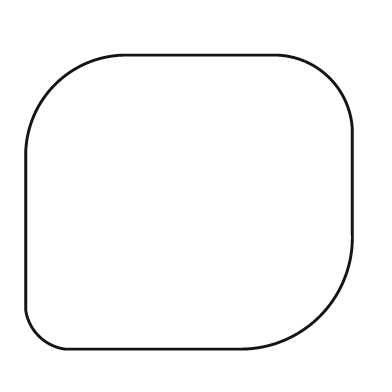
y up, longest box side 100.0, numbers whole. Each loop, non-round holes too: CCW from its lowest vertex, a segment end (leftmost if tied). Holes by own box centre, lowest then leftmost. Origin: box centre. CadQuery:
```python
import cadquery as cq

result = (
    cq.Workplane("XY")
    .moveTo(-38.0, -45.0)
    .lineTo(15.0, -45.0)
    .threePointArc((40.0, -35.0), (50.0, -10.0))
    .lineTo(50.0, 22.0)
    .threePointArc((43.0, 38.0), (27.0, 45.0))
    .lineTo(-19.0, 45.0)
    .threePointArc((-41.0, 36.0), (-50.0, 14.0))
    .lineTo(-50.0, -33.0)
    .threePointArc((-46.0, -41.0), (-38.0, -45.0))
    .close()
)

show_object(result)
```